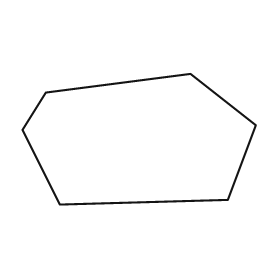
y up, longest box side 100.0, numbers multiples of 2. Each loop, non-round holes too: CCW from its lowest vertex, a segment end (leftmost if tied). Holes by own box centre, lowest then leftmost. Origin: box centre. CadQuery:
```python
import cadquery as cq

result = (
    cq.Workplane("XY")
    .moveTo(-34.0, -28.0)
    .lineTo(38.0, -26.0)
    .lineTo(50.0, 6.0)
    .lineTo(22.0, 28.0)
    .lineTo(-40.0, 20.0)
    .lineTo(-50.0, 4.0)
    .close()
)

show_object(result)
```